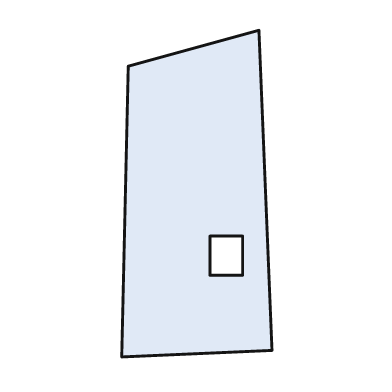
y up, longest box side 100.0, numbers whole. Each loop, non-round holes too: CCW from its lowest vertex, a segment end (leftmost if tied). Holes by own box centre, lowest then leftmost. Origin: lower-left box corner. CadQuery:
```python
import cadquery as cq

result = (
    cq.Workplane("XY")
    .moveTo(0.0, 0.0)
    .lineTo(46.0, 2.0)
    .lineTo(42.0, 100.0)
    .lineTo(2.0, 89.0)
    .close()
    .moveTo(27.0, 25.0)
    .lineTo(37.0, 25.0)
    .lineTo(37.0, 37.0)
    .lineTo(27.0, 37.0)
    .close()
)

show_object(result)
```